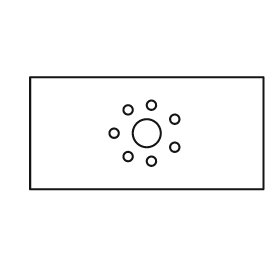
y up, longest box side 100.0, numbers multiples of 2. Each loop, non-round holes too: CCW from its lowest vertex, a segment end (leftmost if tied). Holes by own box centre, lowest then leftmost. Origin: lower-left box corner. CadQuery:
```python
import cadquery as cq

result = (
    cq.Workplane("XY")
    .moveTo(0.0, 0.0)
    .lineTo(100.0, 0.0)
    .lineTo(100.0, 48.0)
    .lineTo(0.0, 48.0)
    .close()
    .moveTo(52.0, 12.0)
    .circle(2.0)
    .moveTo(42.0, 14.0)
    .circle(2.0)
    .moveTo(62.0, 18.0)
    .circle(2.0)
    .moveTo(36.0, 24.0)
    .circle(2.0)
    .moveTo(50.0, 24.0)
    .circle(6.0)
    .moveTo(62.0, 30.0)
    .circle(2.0)
    .moveTo(42.0, 34.0)
    .circle(2.0)
    .moveTo(52.0, 36.0)
    .circle(2.0)
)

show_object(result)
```